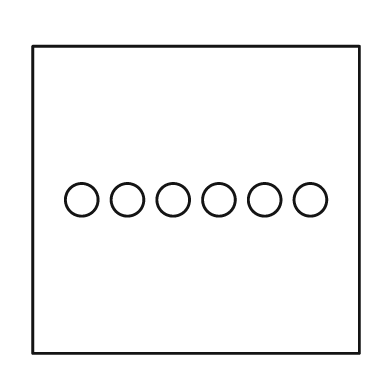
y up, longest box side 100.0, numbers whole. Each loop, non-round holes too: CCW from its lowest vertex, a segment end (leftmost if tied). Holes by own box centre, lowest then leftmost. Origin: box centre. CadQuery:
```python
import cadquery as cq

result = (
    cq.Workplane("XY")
    .moveTo(-50.0, -47.0)
    .lineTo(50.0, -47.0)
    .lineTo(50.0, 47.0)
    .lineTo(-50.0, 47.0)
    .close()
    .moveTo(-35.0, 0.0)
    .circle(5.0)
    .moveTo(-21.0, 0.0)
    .circle(5.0)
    .moveTo(-7.0, 0.0)
    .circle(5.0)
    .moveTo(7.0, 0.0)
    .circle(5.0)
    .moveTo(21.0, 0.0)
    .circle(5.0)
    .moveTo(35.0, 0.0)
    .circle(5.0)
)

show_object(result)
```